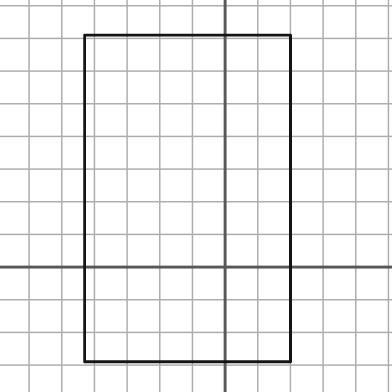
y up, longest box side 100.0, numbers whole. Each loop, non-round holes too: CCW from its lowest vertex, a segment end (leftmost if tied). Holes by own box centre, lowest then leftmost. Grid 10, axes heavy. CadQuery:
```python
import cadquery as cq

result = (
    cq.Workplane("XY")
    .moveTo(-43.0, -29.0)
    .lineTo(20.0, -29.0)
    .lineTo(20.0, 71.0)
    .lineTo(-43.0, 71.0)
    .close()
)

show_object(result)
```